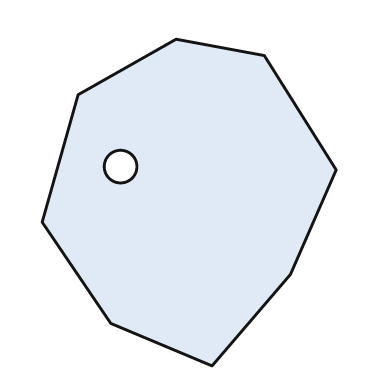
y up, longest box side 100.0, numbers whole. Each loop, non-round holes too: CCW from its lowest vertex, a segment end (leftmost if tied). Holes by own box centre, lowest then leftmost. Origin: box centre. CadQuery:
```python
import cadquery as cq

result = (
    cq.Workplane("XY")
    .moveTo(7.0, -50.0)
    .lineTo(31.0, -22.0)
    .lineTo(45.0, 10.0)
    .lineTo(23.0, 45.0)
    .lineTo(-4.0, 50.0)
    .lineTo(-34.0, 33.0)
    .lineTo(-45.0, -6.0)
    .lineTo(-24.0, -37.0)
    .close()
    .moveTo(-21.0, 11.0)
    .circle(5.0)
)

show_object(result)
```